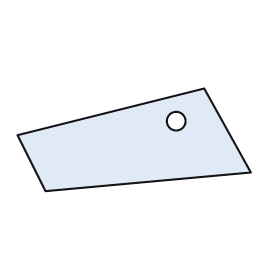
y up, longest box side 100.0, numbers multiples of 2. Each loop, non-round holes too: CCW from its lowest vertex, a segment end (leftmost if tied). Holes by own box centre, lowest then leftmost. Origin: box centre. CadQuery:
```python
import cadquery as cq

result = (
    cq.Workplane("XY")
    .moveTo(-38.0, -22.0)
    .lineTo(50.0, -14.0)
    .lineTo(30.0, 22.0)
    .lineTo(-50.0, 2.0)
    .close()
    .moveTo(18.0, 8.0)
    .circle(4.0)
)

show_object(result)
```